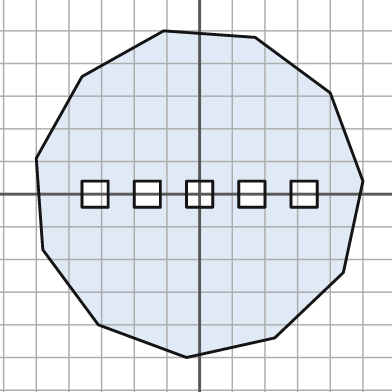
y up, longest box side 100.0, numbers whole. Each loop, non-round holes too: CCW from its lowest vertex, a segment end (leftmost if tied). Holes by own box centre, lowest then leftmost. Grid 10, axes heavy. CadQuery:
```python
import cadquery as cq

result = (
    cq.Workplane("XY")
    .moveTo(-4.0, -50.0)
    .lineTo(23.0, -44.0)
    .lineTo(44.0, -24.0)
    .lineTo(50.0, 4.0)
    .lineTo(40.0, 31.0)
    .lineTo(17.0, 48.0)
    .lineTo(-11.0, 50.0)
    .lineTo(-36.0, 36.0)
    .lineTo(-50.0, 11.0)
    .lineTo(-48.0, -17.0)
    .lineTo(-31.0, -40.0)
    .close()
    .moveTo(-36.0, -4.0)
    .lineTo(-28.0, -4.0)
    .lineTo(-28.0, 4.0)
    .lineTo(-36.0, 4.0)
    .close()
    .moveTo(-20.0, -4.0)
    .lineTo(-12.0, -4.0)
    .lineTo(-12.0, 4.0)
    .lineTo(-20.0, 4.0)
    .close()
    .moveTo(-4.0, -4.0)
    .lineTo(4.0, -4.0)
    .lineTo(4.0, 4.0)
    .lineTo(-4.0, 4.0)
    .close()
    .moveTo(12.0, -4.0)
    .lineTo(20.0, -4.0)
    .lineTo(20.0, 4.0)
    .lineTo(12.0, 4.0)
    .close()
    .moveTo(28.0, -4.0)
    .lineTo(36.0, -4.0)
    .lineTo(36.0, 4.0)
    .lineTo(28.0, 4.0)
    .close()
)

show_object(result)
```